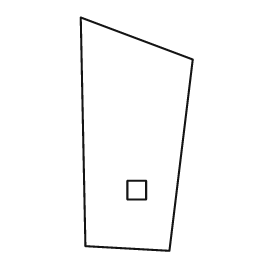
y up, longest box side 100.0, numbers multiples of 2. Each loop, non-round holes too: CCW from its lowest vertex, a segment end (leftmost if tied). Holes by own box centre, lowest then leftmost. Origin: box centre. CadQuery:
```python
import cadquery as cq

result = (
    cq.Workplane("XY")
    .moveTo(14.0, -50.0)
    .lineTo(24.0, 32.0)
    .lineTo(-24.0, 50.0)
    .lineTo(-22.0, -48.0)
    .close()
    .moveTo(-4.0, -28.0)
    .lineTo(4.0, -28.0)
    .lineTo(4.0, -20.0)
    .lineTo(-4.0, -20.0)
    .close()
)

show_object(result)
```